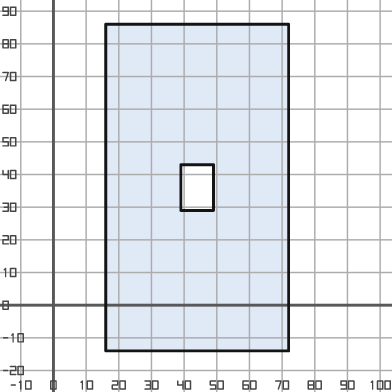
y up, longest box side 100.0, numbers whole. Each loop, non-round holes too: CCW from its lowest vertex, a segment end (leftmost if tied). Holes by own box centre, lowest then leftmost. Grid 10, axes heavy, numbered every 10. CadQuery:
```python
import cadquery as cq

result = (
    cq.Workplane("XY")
    .moveTo(16.0, -14.0)
    .lineTo(72.0, -14.0)
    .lineTo(72.0, 86.0)
    .lineTo(16.0, 86.0)
    .close()
    .moveTo(39.0, 29.0)
    .lineTo(49.0, 29.0)
    .lineTo(49.0, 43.0)
    .lineTo(39.0, 43.0)
    .close()
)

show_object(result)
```